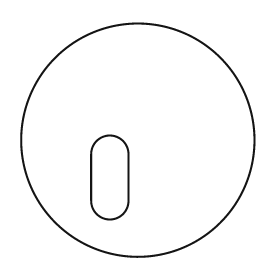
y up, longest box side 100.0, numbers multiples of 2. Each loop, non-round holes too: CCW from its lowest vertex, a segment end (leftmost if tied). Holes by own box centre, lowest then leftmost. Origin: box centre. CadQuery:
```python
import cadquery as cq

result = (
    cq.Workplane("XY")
    .moveTo(0.0, 0.0)
    .circle(50.0)
    .moveTo(-20.0, -26.0)
    .threePointArc((-12.0, -34.0), (-4.0, -26.0))
    .lineTo(-4.0, -6.0)
    .threePointArc((-12.0, 2.0), (-20.0, -6.0))
    .close()
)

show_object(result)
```